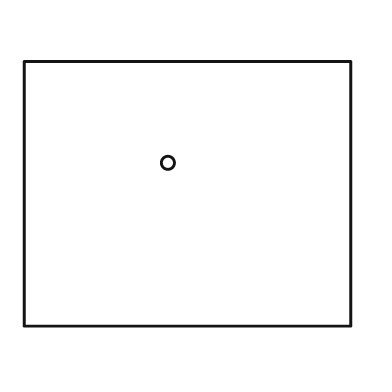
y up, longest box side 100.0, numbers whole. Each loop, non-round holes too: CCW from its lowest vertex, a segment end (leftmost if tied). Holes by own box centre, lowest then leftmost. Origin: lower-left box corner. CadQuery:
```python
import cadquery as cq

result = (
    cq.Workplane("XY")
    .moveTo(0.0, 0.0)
    .lineTo(100.0, 0.0)
    .lineTo(100.0, 81.0)
    .lineTo(0.0, 81.0)
    .close()
    .moveTo(44.0, 50.0)
    .circle(2.0)
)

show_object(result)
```